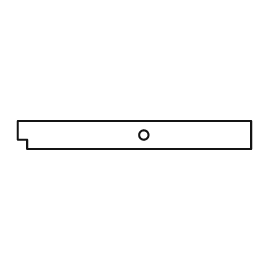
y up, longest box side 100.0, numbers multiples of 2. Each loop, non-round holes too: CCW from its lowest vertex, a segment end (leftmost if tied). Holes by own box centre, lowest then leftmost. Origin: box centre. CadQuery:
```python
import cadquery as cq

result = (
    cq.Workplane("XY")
    .moveTo(-46.0, -6.0)
    .lineTo(50.0, -6.0)
    .lineTo(50.0, 6.0)
    .lineTo(-50.0, 6.0)
    .lineTo(-50.0, -2.0)
    .lineTo(-46.0, -2.0)
    .close()
    .moveTo(4.0, 0.0)
    .circle(2.0)
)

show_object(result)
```